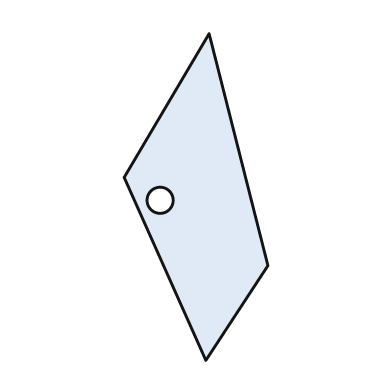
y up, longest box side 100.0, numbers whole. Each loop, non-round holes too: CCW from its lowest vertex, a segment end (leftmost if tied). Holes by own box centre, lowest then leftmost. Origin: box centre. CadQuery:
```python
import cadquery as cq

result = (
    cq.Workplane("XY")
    .moveTo(3.0, -50.0)
    .lineTo(22.0, -21.0)
    .lineTo(4.0, 50.0)
    .lineTo(-22.0, 6.0)
    .close()
    .moveTo(-11.0, -1.0)
    .circle(4.0)
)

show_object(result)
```